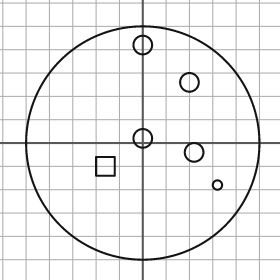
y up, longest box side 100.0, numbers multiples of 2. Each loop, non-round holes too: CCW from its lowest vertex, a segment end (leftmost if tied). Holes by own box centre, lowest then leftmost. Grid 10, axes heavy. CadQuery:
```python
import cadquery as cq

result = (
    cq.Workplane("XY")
    .moveTo(0.0, 0.0)
    .circle(50.0)
    .moveTo(32.0, -18.0)
    .circle(2.0)
    .moveTo(-20.0, -14.0)
    .lineTo(-12.0, -14.0)
    .lineTo(-12.0, -6.0)
    .lineTo(-20.0, -6.0)
    .close()
    .moveTo(22.0, -4.0)
    .circle(4.0)
    .moveTo(0.0, 2.0)
    .circle(4.0)
    .moveTo(20.0, 26.0)
    .circle(4.0)
    .moveTo(0.0, 42.0)
    .circle(4.0)
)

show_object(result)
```